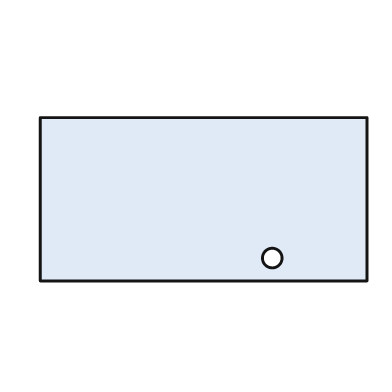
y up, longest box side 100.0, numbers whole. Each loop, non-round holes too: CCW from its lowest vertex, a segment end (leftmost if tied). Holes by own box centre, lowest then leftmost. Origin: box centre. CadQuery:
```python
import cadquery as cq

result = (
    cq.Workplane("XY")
    .moveTo(-50.0, -25.0)
    .lineTo(50.0, -25.0)
    .lineTo(50.0, 25.0)
    .lineTo(-50.0, 25.0)
    .close()
    .moveTo(21.0, -18.0)
    .circle(3.0)
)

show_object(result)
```